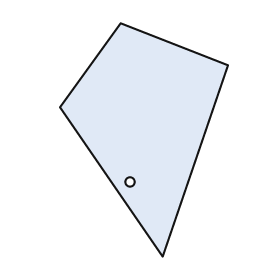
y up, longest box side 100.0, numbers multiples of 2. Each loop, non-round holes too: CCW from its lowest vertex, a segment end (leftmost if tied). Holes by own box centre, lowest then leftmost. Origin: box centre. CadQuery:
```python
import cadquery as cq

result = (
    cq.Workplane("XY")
    .moveTo(8.0, -50.0)
    .lineTo(36.0, 32.0)
    .lineTo(-10.0, 50.0)
    .lineTo(-36.0, 14.0)
    .close()
    .moveTo(-6.0, -18.0)
    .circle(2.0)
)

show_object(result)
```